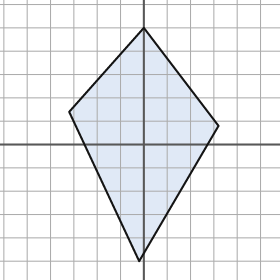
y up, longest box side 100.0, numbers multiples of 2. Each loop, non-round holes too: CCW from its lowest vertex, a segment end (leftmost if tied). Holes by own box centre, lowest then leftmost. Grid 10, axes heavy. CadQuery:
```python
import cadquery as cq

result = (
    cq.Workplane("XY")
    .moveTo(-2.0, -50.0)
    .lineTo(32.0, 8.0)
    .lineTo(0.0, 50.0)
    .lineTo(-32.0, 14.0)
    .close()
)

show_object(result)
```